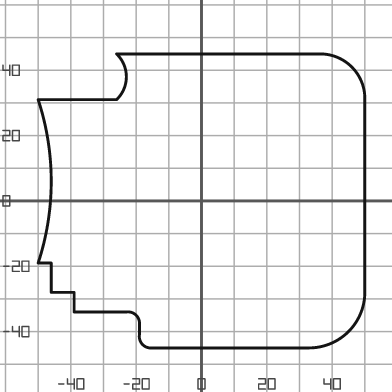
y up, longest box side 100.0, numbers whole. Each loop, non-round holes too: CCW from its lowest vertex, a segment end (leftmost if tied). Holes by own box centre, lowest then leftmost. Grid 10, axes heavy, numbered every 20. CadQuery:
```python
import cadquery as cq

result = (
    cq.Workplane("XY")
    .moveTo(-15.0, -45.0)
    .lineTo(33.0, -45.0)
    .threePointArc((45.0, -40.0), (50.0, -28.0))
    .lineTo(50.0, 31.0)
    .threePointArc((46.0, 41.0), (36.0, 45.0))
    .lineTo(-26.0, 45.0)
    .threePointArc((-23.0, 38.0), (-26.0, 31.0))
    .lineTo(-50.0, 31.0)
    .threePointArc((-46.0, 6.0), (-50.0, -19.0))
    .lineTo(-46.0, -19.0)
    .lineTo(-46.0, -28.0)
    .lineTo(-39.0, -28.0)
    .lineTo(-39.0, -34.0)
    .lineTo(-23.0, -34.0)
    .threePointArc((-20.0, -35.0), (-19.0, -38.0))
    .lineTo(-19.0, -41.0)
    .threePointArc((-18.0, -44.0), (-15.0, -45.0))
    .close()
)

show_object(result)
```